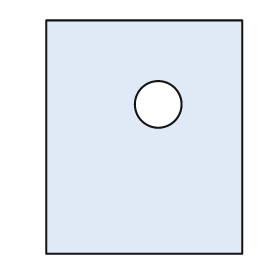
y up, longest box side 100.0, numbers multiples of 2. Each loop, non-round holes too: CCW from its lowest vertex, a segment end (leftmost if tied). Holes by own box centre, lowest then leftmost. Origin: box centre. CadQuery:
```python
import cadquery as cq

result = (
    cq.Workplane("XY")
    .moveTo(-42.0, -50.0)
    .lineTo(42.0, -50.0)
    .lineTo(42.0, 50.0)
    .lineTo(-42.0, 50.0)
    .close()
    .moveTo(6.0, 14.0)
    .circle(10.0)
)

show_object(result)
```